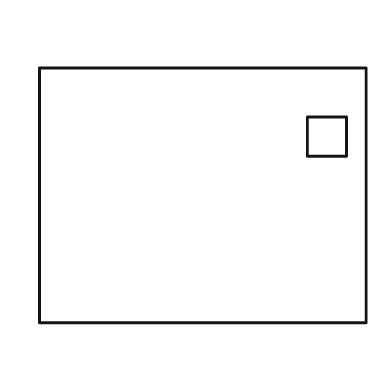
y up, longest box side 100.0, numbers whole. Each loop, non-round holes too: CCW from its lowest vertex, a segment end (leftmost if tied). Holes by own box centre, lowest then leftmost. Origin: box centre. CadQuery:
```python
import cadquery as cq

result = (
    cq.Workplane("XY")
    .moveTo(-50.0, -39.0)
    .lineTo(50.0, -39.0)
    .lineTo(50.0, 39.0)
    .lineTo(-50.0, 39.0)
    .close()
    .moveTo(32.0, 12.0)
    .lineTo(44.0, 12.0)
    .lineTo(44.0, 24.0)
    .lineTo(32.0, 24.0)
    .close()
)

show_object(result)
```